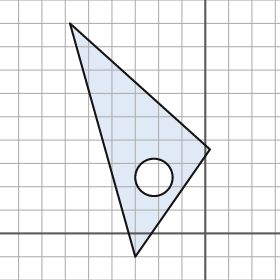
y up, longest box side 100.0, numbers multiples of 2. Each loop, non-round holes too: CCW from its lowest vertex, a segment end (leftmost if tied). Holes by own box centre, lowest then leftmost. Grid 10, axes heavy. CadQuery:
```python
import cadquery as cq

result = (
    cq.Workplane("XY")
    .moveTo(-30.0, -10.0)
    .lineTo(2.0, 36.0)
    .lineTo(-58.0, 90.0)
    .close()
    .moveTo(-22.0, 24.0)
    .circle(8.0)
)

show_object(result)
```